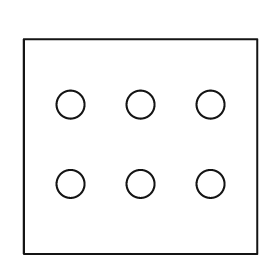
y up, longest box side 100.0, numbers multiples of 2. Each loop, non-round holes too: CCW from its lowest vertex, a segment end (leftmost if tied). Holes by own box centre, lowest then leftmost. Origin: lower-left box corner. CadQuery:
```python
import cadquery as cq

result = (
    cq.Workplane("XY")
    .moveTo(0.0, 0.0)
    .lineTo(100.0, 0.0)
    .lineTo(100.0, 92.0)
    .lineTo(0.0, 92.0)
    .close()
    .moveTo(20.0, 30.0)
    .circle(6.0)
    .moveTo(50.0, 30.0)
    .circle(6.0)
    .moveTo(80.0, 30.0)
    .circle(6.0)
    .moveTo(20.0, 64.0)
    .circle(6.0)
    .moveTo(50.0, 64.0)
    .circle(6.0)
    .moveTo(80.0, 64.0)
    .circle(6.0)
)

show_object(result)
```